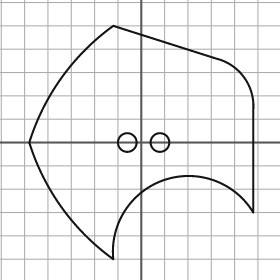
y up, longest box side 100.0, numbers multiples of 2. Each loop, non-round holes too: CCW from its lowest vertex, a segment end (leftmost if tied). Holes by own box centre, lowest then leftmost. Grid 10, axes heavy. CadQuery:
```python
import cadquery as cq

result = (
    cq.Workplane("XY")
    .moveTo(-12.0, -50.0)
    .threePointArc((10.0, -16.0), (48.0, -30.0))
    .lineTo(48.0, 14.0)
    .threePointArc((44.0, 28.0), (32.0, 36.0))
    .lineTo(-12.0, 50.0)
    .threePointArc((-34.0, 28.0), (-48.0, 0.0))
    .threePointArc((-34.0, -28.0), (-12.0, -50.0))
    .close()
    .moveTo(-6.0, 0.0)
    .circle(4.0)
    .moveTo(8.0, 0.0)
    .circle(4.0)
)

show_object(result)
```